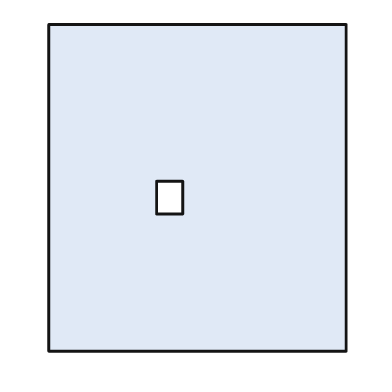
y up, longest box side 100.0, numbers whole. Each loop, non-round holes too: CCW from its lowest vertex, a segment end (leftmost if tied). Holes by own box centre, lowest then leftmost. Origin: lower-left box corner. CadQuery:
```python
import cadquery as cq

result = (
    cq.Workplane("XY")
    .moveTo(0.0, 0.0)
    .lineTo(91.0, 0.0)
    .lineTo(91.0, 100.0)
    .lineTo(0.0, 100.0)
    .close()
    .moveTo(33.0, 42.0)
    .lineTo(41.0, 42.0)
    .lineTo(41.0, 52.0)
    .lineTo(33.0, 52.0)
    .close()
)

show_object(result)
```